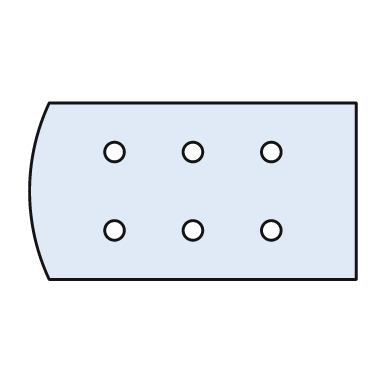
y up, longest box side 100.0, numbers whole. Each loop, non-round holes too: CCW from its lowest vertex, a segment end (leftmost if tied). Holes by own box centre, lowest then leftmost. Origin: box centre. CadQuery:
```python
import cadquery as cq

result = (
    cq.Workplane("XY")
    .moveTo(-44.0, -27.0)
    .lineTo(50.0, -27.0)
    .lineTo(50.0, 27.0)
    .lineTo(-44.0, 27.0)
    .threePointArc((-50.0, 0.0), (-44.0, -27.0))
    .close()
    .moveTo(-24.0, -12.0)
    .circle(3.0)
    .moveTo(0.0, -12.0)
    .circle(3.0)
    .moveTo(24.0, -12.0)
    .circle(3.0)
    .moveTo(-24.0, 12.0)
    .circle(3.0)
    .moveTo(0.0, 12.0)
    .circle(3.0)
    .moveTo(24.0, 12.0)
    .circle(3.0)
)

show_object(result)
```